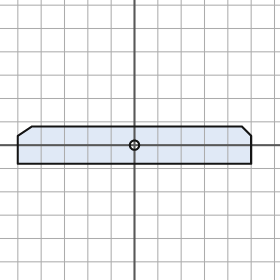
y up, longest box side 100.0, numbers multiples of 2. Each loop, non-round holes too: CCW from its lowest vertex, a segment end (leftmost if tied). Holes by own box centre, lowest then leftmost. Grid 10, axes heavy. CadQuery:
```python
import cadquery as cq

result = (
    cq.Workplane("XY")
    .moveTo(-50.0, -8.0)
    .lineTo(50.0, -8.0)
    .lineTo(50.0, 4.0)
    .lineTo(46.0, 8.0)
    .lineTo(-44.0, 8.0)
    .lineTo(-50.0, 4.0)
    .close()
    .moveTo(0.0, 0.0)
    .circle(2.0)
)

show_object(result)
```